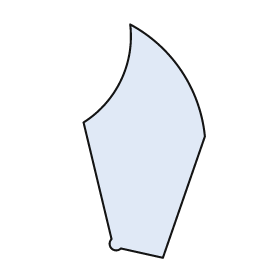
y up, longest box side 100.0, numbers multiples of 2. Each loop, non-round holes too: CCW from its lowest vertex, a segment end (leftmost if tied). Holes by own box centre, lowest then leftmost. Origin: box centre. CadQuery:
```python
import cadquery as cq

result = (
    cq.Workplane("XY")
    .moveTo(8.0, -50.0)
    .lineTo(26.0, 2.0)
    .threePointArc((16.0, 30.0), (-6.0, 50.0))
    .threePointArc((-10.0, 26.0), (-26.0, 8.0))
    .lineTo(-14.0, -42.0)
    .threePointArc((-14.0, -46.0), (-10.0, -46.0))
    .close()
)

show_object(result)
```